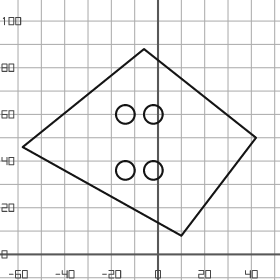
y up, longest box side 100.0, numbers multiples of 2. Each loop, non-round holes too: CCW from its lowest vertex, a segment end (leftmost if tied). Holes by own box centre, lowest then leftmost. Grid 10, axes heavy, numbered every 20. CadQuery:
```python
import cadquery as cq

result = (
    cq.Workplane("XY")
    .moveTo(10.0, 8.0)
    .lineTo(42.0, 50.0)
    .lineTo(-6.0, 88.0)
    .lineTo(-58.0, 46.0)
    .close()
    .moveTo(-14.0, 36.0)
    .circle(4.0)
    .moveTo(-2.0, 36.0)
    .circle(4.0)
    .moveTo(-14.0, 60.0)
    .circle(4.0)
    .moveTo(-2.0, 60.0)
    .circle(4.0)
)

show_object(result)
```